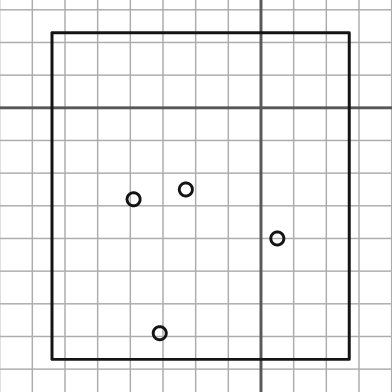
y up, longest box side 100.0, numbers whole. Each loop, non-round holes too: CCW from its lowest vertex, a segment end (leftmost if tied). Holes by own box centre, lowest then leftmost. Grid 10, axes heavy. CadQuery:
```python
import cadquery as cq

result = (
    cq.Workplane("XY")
    .moveTo(-64.0, -77.0)
    .lineTo(27.0, -77.0)
    .lineTo(27.0, 23.0)
    .lineTo(-64.0, 23.0)
    .close()
    .moveTo(-31.0, -69.0)
    .circle(2.0)
    .moveTo(5.0, -40.0)
    .circle(2.0)
    .moveTo(-39.0, -28.0)
    .circle(2.0)
    .moveTo(-23.0, -25.0)
    .circle(2.0)
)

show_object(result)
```